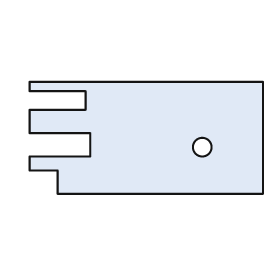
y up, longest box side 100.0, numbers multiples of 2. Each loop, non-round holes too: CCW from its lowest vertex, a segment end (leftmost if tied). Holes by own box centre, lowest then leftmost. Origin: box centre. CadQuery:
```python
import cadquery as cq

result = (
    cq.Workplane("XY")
    .moveTo(-38.0, -24.0)
    .lineTo(50.0, -24.0)
    .lineTo(50.0, 24.0)
    .lineTo(-50.0, 24.0)
    .lineTo(-50.0, 20.0)
    .lineTo(-26.0, 20.0)
    .lineTo(-26.0, 12.0)
    .lineTo(-50.0, 12.0)
    .lineTo(-50.0, 2.0)
    .lineTo(-24.0, 2.0)
    .lineTo(-24.0, -8.0)
    .lineTo(-50.0, -8.0)
    .lineTo(-50.0, -14.0)
    .lineTo(-38.0, -14.0)
    .close()
    .moveTo(24.0, -4.0)
    .circle(4.0)
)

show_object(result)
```